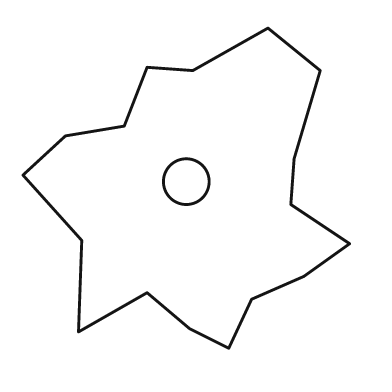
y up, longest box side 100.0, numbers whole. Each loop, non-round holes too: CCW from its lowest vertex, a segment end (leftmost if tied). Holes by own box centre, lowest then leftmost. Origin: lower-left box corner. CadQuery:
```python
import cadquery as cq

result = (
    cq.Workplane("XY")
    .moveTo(63.0, 0.0)
    .lineTo(70.0, 15.0)
    .lineTo(86.0, 22.0)
    .lineTo(100.0, 32.0)
    .lineTo(82.0, 44.0)
    .lineTo(83.0, 58.0)
    .lineTo(91.0, 85.0)
    .lineTo(75.0, 98.0)
    .lineTo(52.0, 85.0)
    .lineTo(38.0, 86.0)
    .lineTo(31.0, 68.0)
    .lineTo(13.0, 65.0)
    .lineTo(0.0, 53.0)
    .lineTo(18.0, 33.0)
    .lineTo(17.0, 5.0)
    .lineTo(38.0, 17.0)
    .lineTo(51.0, 6.0)
    .close()
    .moveTo(50.0, 51.0)
    .circle(7.0)
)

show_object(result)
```